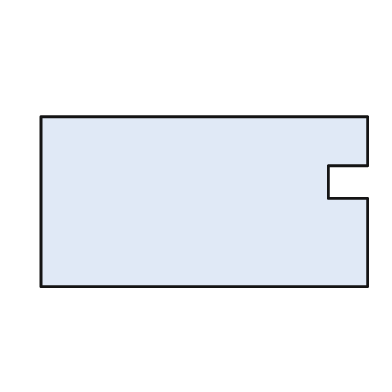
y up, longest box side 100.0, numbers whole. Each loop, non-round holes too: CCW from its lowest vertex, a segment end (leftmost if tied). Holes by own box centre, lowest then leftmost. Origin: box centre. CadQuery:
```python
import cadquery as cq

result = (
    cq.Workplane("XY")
    .moveTo(-50.0, -26.0)
    .lineTo(50.0, -26.0)
    .lineTo(50.0, 1.0)
    .lineTo(38.0, 1.0)
    .lineTo(38.0, 11.0)
    .lineTo(50.0, 11.0)
    .lineTo(50.0, 26.0)
    .lineTo(-50.0, 26.0)
    .close()
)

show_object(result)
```